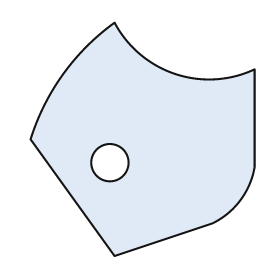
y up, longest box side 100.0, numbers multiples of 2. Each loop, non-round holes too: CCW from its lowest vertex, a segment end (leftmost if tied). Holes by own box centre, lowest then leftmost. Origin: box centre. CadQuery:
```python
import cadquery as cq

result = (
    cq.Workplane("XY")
    .moveTo(-12.0, -50.0)
    .lineTo(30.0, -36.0)
    .threePointArc((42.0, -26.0), (48.0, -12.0))
    .lineTo(48.0, 30.0)
    .threePointArc((14.0, 28.0), (-12.0, 50.0))
    .threePointArc((-34.0, 28.0), (-48.0, 0.0))
    .close()
    .moveTo(-14.0, -10.0)
    .circle(8.0)
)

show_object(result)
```